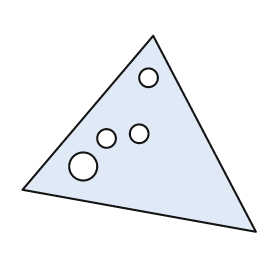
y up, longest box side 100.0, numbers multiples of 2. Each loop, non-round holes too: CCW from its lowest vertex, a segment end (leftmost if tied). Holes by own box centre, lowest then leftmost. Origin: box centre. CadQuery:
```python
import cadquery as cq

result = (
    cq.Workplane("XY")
    .moveTo(50.0, -42.0)
    .lineTo(6.0, 42.0)
    .lineTo(-50.0, -24.0)
    .close()
    .moveTo(-24.0, -14.0)
    .circle(6.0)
    .moveTo(-14.0, -2.0)
    .circle(4.0)
    .moveTo(0.0, 0.0)
    .circle(4.0)
    .moveTo(4.0, 24.0)
    .circle(4.0)
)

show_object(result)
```